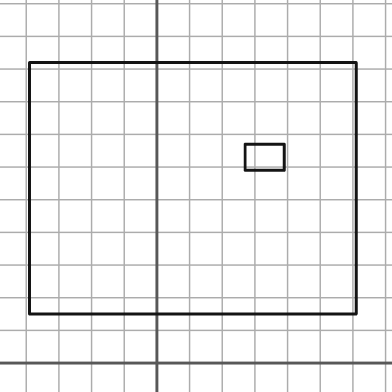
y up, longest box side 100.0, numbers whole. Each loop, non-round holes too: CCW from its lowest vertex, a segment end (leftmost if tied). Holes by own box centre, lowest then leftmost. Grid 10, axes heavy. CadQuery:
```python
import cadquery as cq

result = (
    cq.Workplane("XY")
    .moveTo(-39.0, 15.0)
    .lineTo(61.0, 15.0)
    .lineTo(61.0, 92.0)
    .lineTo(-39.0, 92.0)
    .close()
    .moveTo(27.0, 59.0)
    .lineTo(39.0, 59.0)
    .lineTo(39.0, 67.0)
    .lineTo(27.0, 67.0)
    .close()
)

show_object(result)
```